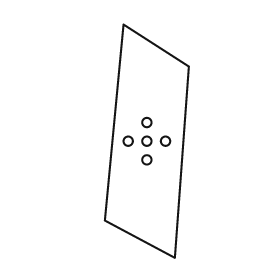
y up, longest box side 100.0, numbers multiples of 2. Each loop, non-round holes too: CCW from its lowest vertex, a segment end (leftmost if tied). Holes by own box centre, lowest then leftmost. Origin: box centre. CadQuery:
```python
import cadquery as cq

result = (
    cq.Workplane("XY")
    .moveTo(12.0, -50.0)
    .lineTo(18.0, 32.0)
    .lineTo(-10.0, 50.0)
    .lineTo(-18.0, -34.0)
    .close()
    .moveTo(0.0, -8.0)
    .circle(2.0)
    .moveTo(-8.0, 0.0)
    .circle(2.0)
    .moveTo(0.0, 0.0)
    .circle(2.0)
    .moveTo(8.0, 0.0)
    .circle(2.0)
    .moveTo(0.0, 8.0)
    .circle(2.0)
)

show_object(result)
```